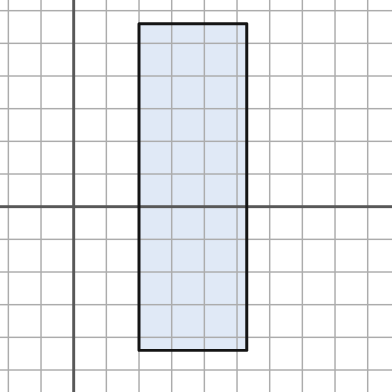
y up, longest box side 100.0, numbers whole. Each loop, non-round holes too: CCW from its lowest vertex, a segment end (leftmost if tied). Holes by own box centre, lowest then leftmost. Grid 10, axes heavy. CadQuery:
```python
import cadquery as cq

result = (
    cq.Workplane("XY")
    .moveTo(20.0, -44.0)
    .lineTo(53.0, -44.0)
    .lineTo(53.0, 56.0)
    .lineTo(20.0, 56.0)
    .close()
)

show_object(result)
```